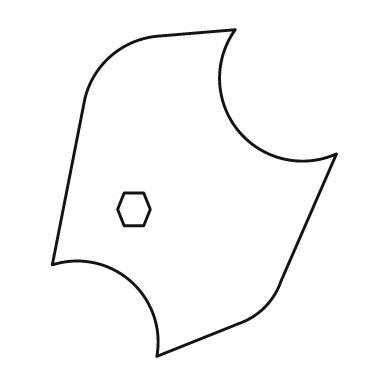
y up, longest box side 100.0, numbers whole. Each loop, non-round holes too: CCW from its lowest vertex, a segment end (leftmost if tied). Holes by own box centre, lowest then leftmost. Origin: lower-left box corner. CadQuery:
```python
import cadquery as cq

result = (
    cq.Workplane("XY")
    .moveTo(32.0, 0.0)
    .lineTo(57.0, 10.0)
    .threePointArc((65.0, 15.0), (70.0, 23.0))
    .lineTo(87.0, 62.0)
    .threePointArc((57.0, 69.0), (56.0, 100.0))
    .lineTo(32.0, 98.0)
    .threePointArc((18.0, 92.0), (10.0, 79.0))
    .lineTo(0.0, 28.0)
    .threePointArc((24.0, 23.0), (32.0, 0.0))
    .close()
    .moveTo(22.0, 40.0)
    .lineTo(28.0, 40.0)
    .lineTo(30.0, 45.0)
    .lineTo(28.0, 50.0)
    .lineTo(22.0, 50.0)
    .lineTo(20.0, 45.0)
    .close()
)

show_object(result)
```